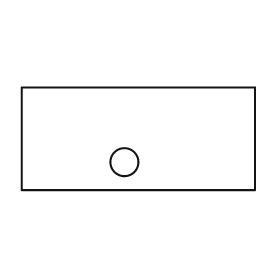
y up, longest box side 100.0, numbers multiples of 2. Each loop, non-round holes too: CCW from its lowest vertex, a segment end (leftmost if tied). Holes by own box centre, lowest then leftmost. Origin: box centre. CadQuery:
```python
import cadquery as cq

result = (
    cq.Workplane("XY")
    .moveTo(-50.0, -22.0)
    .lineTo(50.0, -22.0)
    .lineTo(50.0, 22.0)
    .lineTo(-50.0, 22.0)
    .close()
    .moveTo(-6.0, -10.0)
    .circle(6.0)
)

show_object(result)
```